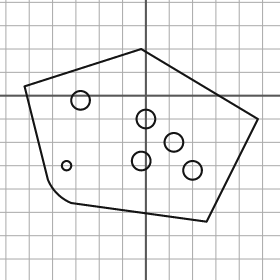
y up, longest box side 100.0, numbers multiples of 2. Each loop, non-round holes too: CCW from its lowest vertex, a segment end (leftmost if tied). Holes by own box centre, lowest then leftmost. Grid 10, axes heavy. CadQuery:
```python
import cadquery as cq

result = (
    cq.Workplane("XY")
    .moveTo(26.0, -54.0)
    .lineTo(48.0, -10.0)
    .lineTo(-2.0, 20.0)
    .lineTo(-52.0, 4.0)
    .lineTo(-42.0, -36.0)
    .threePointArc((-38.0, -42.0), (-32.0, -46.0))
    .close()
    .moveTo(20.0, -32.0)
    .circle(4.0)
    .moveTo(-34.0, -30.0)
    .circle(2.0)
    .moveTo(-2.0, -28.0)
    .circle(4.0)
    .moveTo(12.0, -20.0)
    .circle(4.0)
    .moveTo(0.0, -10.0)
    .circle(4.0)
    .moveTo(-28.0, -2.0)
    .circle(4.0)
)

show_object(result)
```